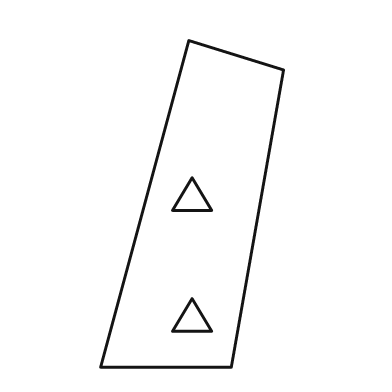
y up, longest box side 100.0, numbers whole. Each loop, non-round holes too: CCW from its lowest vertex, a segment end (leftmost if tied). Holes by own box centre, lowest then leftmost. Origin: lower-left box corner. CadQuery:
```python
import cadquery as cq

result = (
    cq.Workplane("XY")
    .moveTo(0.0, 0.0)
    .lineTo(40.0, 0.0)
    .lineTo(56.0, 91.0)
    .lineTo(27.0, 100.0)
    .close()
    .moveTo(22.0, 11.0)
    .lineTo(34.0, 11.0)
    .lineTo(28.0, 21.0)
    .close()
    .moveTo(22.0, 48.0)
    .lineTo(34.0, 48.0)
    .lineTo(28.0, 58.0)
    .close()
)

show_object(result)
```